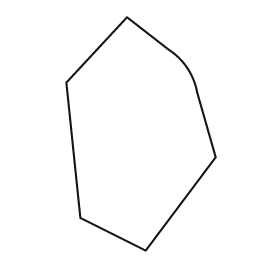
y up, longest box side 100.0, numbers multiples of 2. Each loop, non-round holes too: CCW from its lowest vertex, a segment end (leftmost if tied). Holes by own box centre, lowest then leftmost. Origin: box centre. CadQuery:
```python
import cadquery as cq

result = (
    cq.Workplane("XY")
    .moveTo(2.0, -50.0)
    .lineTo(32.0, -10.0)
    .lineTo(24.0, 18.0)
    .threePointArc((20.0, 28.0), (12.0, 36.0))
    .lineTo(-6.0, 50.0)
    .lineTo(-32.0, 22.0)
    .lineTo(-26.0, -36.0)
    .close()
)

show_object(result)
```